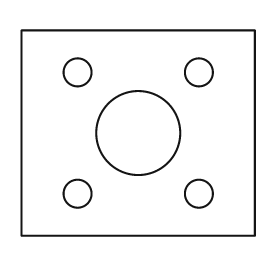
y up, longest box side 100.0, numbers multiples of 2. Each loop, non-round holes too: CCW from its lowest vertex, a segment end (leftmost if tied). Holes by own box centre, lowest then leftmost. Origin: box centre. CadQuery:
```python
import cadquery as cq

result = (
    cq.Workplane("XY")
    .moveTo(-50.0, -44.0)
    .lineTo(50.0, -44.0)
    .lineTo(50.0, 44.0)
    .lineTo(-50.0, 44.0)
    .close()
    .moveTo(-26.0, -26.0)
    .circle(6.0)
    .moveTo(26.0, -26.0)
    .circle(6.0)
    .moveTo(0.0, 0.0)
    .circle(18.0)
    .moveTo(-26.0, 26.0)
    .circle(6.0)
    .moveTo(26.0, 26.0)
    .circle(6.0)
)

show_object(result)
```